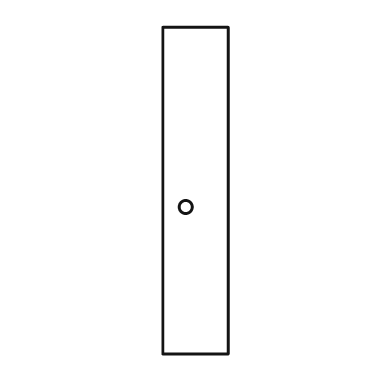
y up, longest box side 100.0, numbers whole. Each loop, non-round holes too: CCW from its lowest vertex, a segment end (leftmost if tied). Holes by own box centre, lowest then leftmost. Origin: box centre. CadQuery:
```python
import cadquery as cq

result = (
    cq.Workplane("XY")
    .moveTo(-10.0, -50.0)
    .lineTo(10.0, -50.0)
    .lineTo(10.0, 50.0)
    .lineTo(-10.0, 50.0)
    .close()
    .moveTo(-3.0, -5.0)
    .circle(2.0)
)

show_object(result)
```